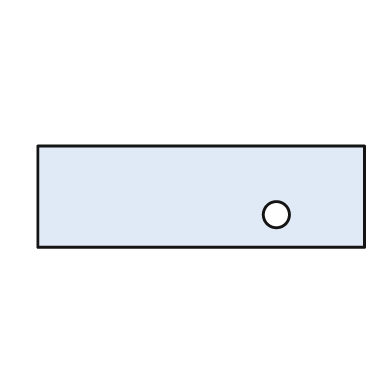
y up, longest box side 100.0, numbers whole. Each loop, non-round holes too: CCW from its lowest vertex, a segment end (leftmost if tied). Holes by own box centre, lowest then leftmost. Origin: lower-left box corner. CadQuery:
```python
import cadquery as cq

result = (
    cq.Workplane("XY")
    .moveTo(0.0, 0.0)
    .lineTo(100.0, 0.0)
    .lineTo(100.0, 31.0)
    .lineTo(0.0, 31.0)
    .close()
    .moveTo(73.0, 10.0)
    .circle(4.0)
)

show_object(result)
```